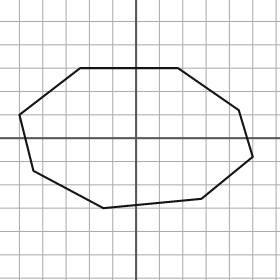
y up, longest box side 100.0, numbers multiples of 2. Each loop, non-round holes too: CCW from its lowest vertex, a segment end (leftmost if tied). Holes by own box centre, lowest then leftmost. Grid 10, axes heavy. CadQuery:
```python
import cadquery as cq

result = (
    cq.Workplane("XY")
    .moveTo(-14.0, -30.0)
    .lineTo(28.0, -26.0)
    .lineTo(50.0, -8.0)
    .lineTo(44.0, 12.0)
    .lineTo(18.0, 30.0)
    .lineTo(-24.0, 30.0)
    .lineTo(-50.0, 10.0)
    .lineTo(-44.0, -14.0)
    .close()
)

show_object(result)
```